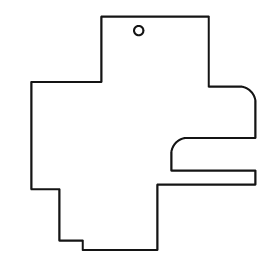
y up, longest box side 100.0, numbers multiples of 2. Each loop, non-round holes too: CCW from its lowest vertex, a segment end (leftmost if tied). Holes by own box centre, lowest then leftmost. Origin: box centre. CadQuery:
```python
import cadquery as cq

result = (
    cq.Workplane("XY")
    .moveTo(-26.0, -50.0)
    .lineTo(6.0, -50.0)
    .lineTo(6.0, -22.0)
    .lineTo(48.0, -22.0)
    .lineTo(48.0, -16.0)
    .lineTo(12.0, -16.0)
    .lineTo(12.0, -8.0)
    .threePointArc((14.0, -4.0), (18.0, -2.0))
    .lineTo(48.0, -2.0)
    .lineTo(48.0, 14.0)
    .threePointArc((46.0, 18.0), (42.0, 20.0))
    .lineTo(28.0, 20.0)
    .lineTo(28.0, 50.0)
    .lineTo(-18.0, 50.0)
    .lineTo(-18.0, 22.0)
    .lineTo(-48.0, 22.0)
    .lineTo(-48.0, -24.0)
    .lineTo(-36.0, -24.0)
    .lineTo(-36.0, -46.0)
    .lineTo(-26.0, -46.0)
    .close()
    .moveTo(-2.0, 44.0)
    .circle(2.0)
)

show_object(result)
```